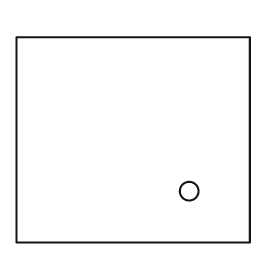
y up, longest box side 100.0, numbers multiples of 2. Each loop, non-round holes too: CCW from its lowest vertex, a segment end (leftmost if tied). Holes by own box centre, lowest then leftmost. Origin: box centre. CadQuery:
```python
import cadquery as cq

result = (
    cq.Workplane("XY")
    .moveTo(-50.0, -44.0)
    .lineTo(50.0, -44.0)
    .lineTo(50.0, 44.0)
    .lineTo(-50.0, 44.0)
    .close()
    .moveTo(24.0, -22.0)
    .circle(4.0)
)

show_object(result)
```